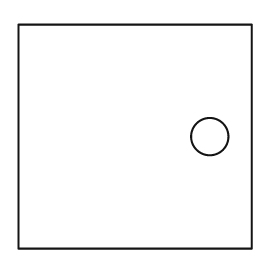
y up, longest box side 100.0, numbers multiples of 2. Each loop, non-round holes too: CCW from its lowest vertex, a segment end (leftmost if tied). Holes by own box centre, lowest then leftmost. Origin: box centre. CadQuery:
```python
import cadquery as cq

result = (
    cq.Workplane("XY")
    .moveTo(-50.0, -48.0)
    .lineTo(50.0, -48.0)
    .lineTo(50.0, 48.0)
    .lineTo(-50.0, 48.0)
    .close()
    .moveTo(32.0, 0.0)
    .circle(8.0)
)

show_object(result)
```